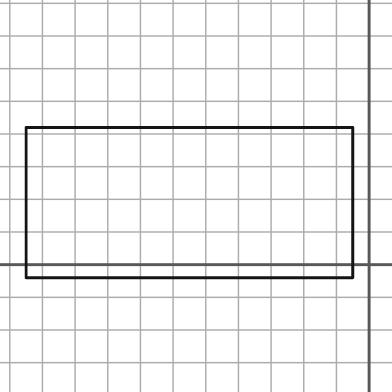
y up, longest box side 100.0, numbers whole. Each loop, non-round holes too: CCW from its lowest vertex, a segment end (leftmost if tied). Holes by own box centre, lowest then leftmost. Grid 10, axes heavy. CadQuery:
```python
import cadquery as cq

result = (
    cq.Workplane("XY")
    .moveTo(-105.0, -4.0)
    .lineTo(-5.0, -4.0)
    .lineTo(-5.0, 42.0)
    .lineTo(-105.0, 42.0)
    .close()
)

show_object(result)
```